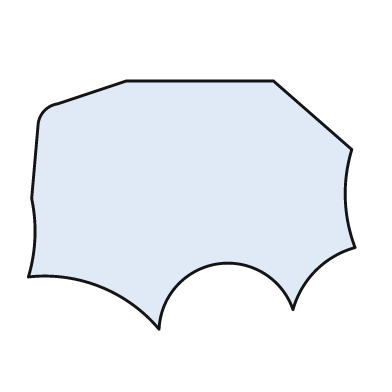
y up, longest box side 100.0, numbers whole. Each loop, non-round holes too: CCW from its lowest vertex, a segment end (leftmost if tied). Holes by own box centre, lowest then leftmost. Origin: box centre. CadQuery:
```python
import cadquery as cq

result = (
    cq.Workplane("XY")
    .moveTo(-10.0, -38.0)
    .threePointArc((8.0, -18.0), (31.0, -32.0))
    .threePointArc((38.0, -20.0), (50.0, -13.0))
    .threePointArc((47.0, 2.0), (49.0, 17.0))
    .lineTo(25.0, 38.0)
    .lineTo(-20.0, 38.0)
    .lineTo(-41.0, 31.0)
    .threePointArc((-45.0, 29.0), (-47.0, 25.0))
    .lineTo(-49.0, 2.0)
    .threePointArc((-48.0, -10.0), (-50.0, -22.0))
    .threePointArc((-28.0, -25.0), (-10.0, -38.0))
    .close()
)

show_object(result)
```